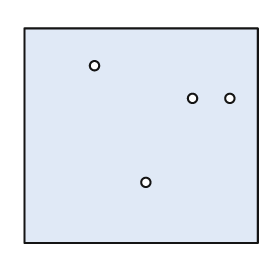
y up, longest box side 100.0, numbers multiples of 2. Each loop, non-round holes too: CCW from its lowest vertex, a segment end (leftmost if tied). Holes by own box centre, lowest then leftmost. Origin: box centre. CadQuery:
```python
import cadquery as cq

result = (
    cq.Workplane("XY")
    .moveTo(-50.0, -46.0)
    .lineTo(50.0, -46.0)
    .lineTo(50.0, 46.0)
    .lineTo(-50.0, 46.0)
    .close()
    .moveTo(2.0, -20.0)
    .circle(2.0)
    .moveTo(22.0, 16.0)
    .circle(2.0)
    .moveTo(38.0, 16.0)
    .circle(2.0)
    .moveTo(-20.0, 30.0)
    .circle(2.0)
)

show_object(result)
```